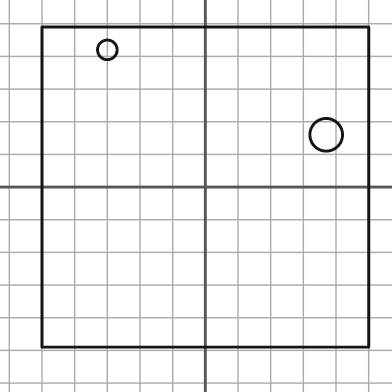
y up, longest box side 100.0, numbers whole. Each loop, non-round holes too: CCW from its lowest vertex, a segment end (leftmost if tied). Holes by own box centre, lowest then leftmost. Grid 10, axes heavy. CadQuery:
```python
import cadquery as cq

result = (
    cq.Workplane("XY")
    .moveTo(-50.0, -49.0)
    .lineTo(50.0, -49.0)
    .lineTo(50.0, 49.0)
    .lineTo(-50.0, 49.0)
    .close()
    .moveTo(37.0, 16.0)
    .circle(5.0)
    .moveTo(-30.0, 42.0)
    .circle(3.0)
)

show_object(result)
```